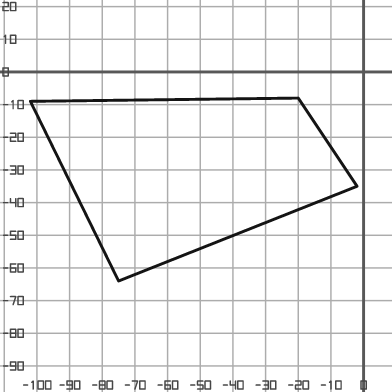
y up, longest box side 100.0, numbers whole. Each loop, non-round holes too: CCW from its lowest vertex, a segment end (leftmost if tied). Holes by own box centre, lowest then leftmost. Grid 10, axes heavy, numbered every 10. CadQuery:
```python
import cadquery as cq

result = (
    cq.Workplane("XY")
    .moveTo(-75.0, -64.0)
    .lineTo(-2.0, -35.0)
    .lineTo(-20.0, -8.0)
    .lineTo(-102.0, -9.0)
    .close()
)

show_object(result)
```